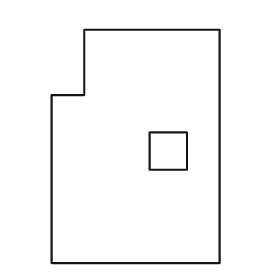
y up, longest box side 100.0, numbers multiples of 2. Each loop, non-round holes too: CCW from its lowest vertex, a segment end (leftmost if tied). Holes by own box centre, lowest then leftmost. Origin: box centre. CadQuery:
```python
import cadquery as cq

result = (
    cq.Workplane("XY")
    .moveTo(-36.0, -50.0)
    .lineTo(36.0, -50.0)
    .lineTo(36.0, 50.0)
    .lineTo(-22.0, 50.0)
    .lineTo(-22.0, 22.0)
    .lineTo(-36.0, 22.0)
    .close()
    .moveTo(6.0, -10.0)
    .lineTo(22.0, -10.0)
    .lineTo(22.0, 6.0)
    .lineTo(6.0, 6.0)
    .close()
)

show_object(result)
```